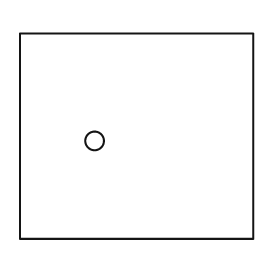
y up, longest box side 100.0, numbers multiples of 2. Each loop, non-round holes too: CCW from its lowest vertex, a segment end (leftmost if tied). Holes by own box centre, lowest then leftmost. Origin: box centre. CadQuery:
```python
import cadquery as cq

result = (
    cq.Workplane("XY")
    .moveTo(-50.0, -44.0)
    .lineTo(50.0, -44.0)
    .lineTo(50.0, 44.0)
    .lineTo(-50.0, 44.0)
    .close()
    .moveTo(-18.0, -2.0)
    .circle(4.0)
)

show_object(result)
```